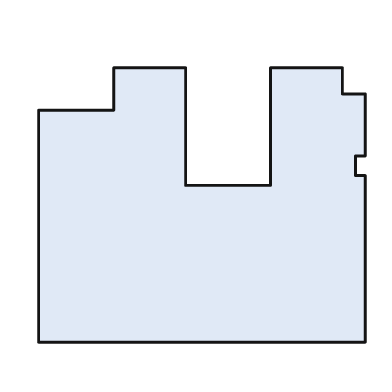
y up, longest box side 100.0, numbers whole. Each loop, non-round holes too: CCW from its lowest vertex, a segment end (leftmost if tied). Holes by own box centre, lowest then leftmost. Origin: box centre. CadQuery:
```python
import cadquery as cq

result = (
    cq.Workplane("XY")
    .moveTo(-50.0, -42.0)
    .lineTo(50.0, -42.0)
    .lineTo(50.0, 9.0)
    .lineTo(47.0, 9.0)
    .lineTo(47.0, 15.0)
    .lineTo(50.0, 15.0)
    .lineTo(50.0, 34.0)
    .lineTo(43.0, 34.0)
    .lineTo(43.0, 42.0)
    .lineTo(21.0, 42.0)
    .lineTo(21.0, 6.0)
    .lineTo(-5.0, 6.0)
    .lineTo(-5.0, 42.0)
    .lineTo(-27.0, 42.0)
    .lineTo(-27.0, 29.0)
    .lineTo(-50.0, 29.0)
    .close()
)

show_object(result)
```